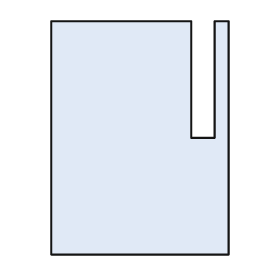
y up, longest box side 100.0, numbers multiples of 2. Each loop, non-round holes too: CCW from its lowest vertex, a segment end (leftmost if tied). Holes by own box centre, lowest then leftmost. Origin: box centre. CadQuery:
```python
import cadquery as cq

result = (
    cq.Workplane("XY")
    .moveTo(-38.0, -50.0)
    .lineTo(38.0, -50.0)
    .lineTo(38.0, 50.0)
    .lineTo(32.0, 50.0)
    .lineTo(32.0, 0.0)
    .lineTo(22.0, 0.0)
    .lineTo(22.0, 50.0)
    .lineTo(-38.0, 50.0)
    .close()
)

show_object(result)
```